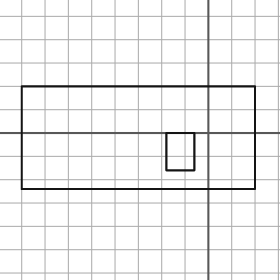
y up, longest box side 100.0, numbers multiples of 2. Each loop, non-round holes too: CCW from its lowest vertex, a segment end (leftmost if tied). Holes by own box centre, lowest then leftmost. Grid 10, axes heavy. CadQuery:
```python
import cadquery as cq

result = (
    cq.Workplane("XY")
    .moveTo(-80.0, -24.0)
    .lineTo(20.0, -24.0)
    .lineTo(20.0, 20.0)
    .lineTo(-80.0, 20.0)
    .close()
    .moveTo(-18.0, -16.0)
    .lineTo(-6.0, -16.0)
    .lineTo(-6.0, 0.0)
    .lineTo(-18.0, 0.0)
    .close()
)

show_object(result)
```